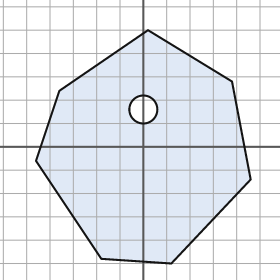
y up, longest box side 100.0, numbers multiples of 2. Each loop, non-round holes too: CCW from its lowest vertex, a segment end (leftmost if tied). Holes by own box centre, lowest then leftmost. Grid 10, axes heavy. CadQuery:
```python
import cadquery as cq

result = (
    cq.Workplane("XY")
    .moveTo(12.0, -50.0)
    .lineTo(46.0, -14.0)
    .lineTo(38.0, 28.0)
    .lineTo(2.0, 50.0)
    .lineTo(-36.0, 24.0)
    .lineTo(-46.0, -6.0)
    .lineTo(-18.0, -48.0)
    .close()
    .moveTo(0.0, 16.0)
    .circle(6.0)
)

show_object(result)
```